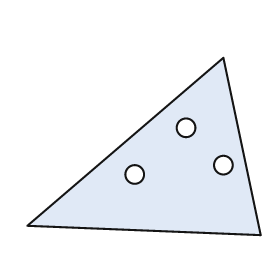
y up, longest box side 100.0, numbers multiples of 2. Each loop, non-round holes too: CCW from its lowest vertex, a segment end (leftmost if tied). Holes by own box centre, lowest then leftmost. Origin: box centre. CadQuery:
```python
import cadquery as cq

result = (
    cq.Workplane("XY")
    .moveTo(50.0, -38.0)
    .lineTo(34.0, 38.0)
    .lineTo(-50.0, -34.0)
    .close()
    .moveTo(-4.0, -12.0)
    .circle(4.0)
    .moveTo(34.0, -8.0)
    .circle(4.0)
    .moveTo(18.0, 8.0)
    .circle(4.0)
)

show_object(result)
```